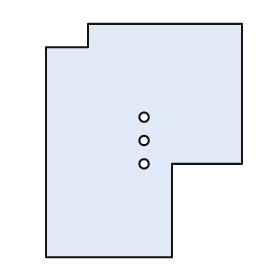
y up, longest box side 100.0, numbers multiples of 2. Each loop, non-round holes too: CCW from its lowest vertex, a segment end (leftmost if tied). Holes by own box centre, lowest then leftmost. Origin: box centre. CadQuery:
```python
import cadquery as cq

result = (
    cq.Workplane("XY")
    .moveTo(-42.0, -50.0)
    .lineTo(12.0, -50.0)
    .lineTo(12.0, -10.0)
    .lineTo(42.0, -10.0)
    .lineTo(42.0, 50.0)
    .lineTo(-24.0, 50.0)
    .lineTo(-24.0, 40.0)
    .lineTo(-42.0, 40.0)
    .close()
    .moveTo(0.0, -10.0)
    .circle(2.0)
    .moveTo(0.0, 0.0)
    .circle(2.0)
    .moveTo(0.0, 10.0)
    .circle(2.0)
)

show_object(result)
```